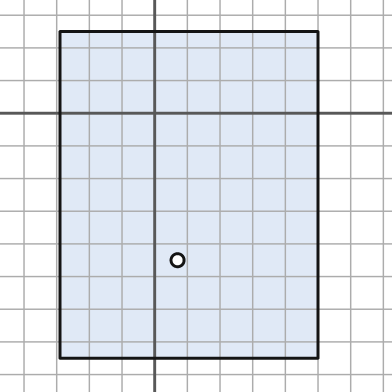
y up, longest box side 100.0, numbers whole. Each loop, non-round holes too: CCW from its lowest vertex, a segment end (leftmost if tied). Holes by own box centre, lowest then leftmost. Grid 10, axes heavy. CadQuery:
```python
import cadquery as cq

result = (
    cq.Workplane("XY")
    .moveTo(-29.0, -75.0)
    .lineTo(50.0, -75.0)
    .lineTo(50.0, 25.0)
    .lineTo(-29.0, 25.0)
    .close()
    .moveTo(7.0, -45.0)
    .circle(2.0)
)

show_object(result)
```